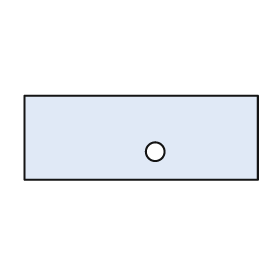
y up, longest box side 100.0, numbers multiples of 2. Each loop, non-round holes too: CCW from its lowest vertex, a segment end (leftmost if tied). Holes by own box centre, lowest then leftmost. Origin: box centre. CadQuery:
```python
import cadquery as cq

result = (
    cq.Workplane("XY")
    .moveTo(-50.0, -18.0)
    .lineTo(50.0, -18.0)
    .lineTo(50.0, 18.0)
    .lineTo(-50.0, 18.0)
    .close()
    .moveTo(6.0, -6.0)
    .circle(4.0)
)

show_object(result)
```